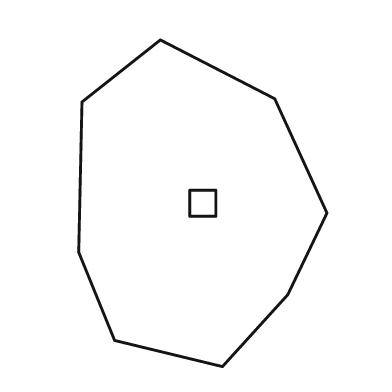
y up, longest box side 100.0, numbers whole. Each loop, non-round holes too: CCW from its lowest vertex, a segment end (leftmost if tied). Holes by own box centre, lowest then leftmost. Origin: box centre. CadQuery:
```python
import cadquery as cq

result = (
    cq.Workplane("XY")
    .moveTo(6.0, -50.0)
    .lineTo(26.0, -28.0)
    .lineTo(38.0, -3.0)
    .lineTo(22.0, 32.0)
    .lineTo(-13.0, 50.0)
    .lineTo(-37.0, 31.0)
    .lineTo(-38.0, -15.0)
    .lineTo(-27.0, -42.0)
    .close()
    .moveTo(-4.0, -4.0)
    .lineTo(4.0, -4.0)
    .lineTo(4.0, 4.0)
    .lineTo(-4.0, 4.0)
    .close()
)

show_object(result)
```